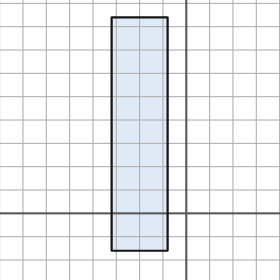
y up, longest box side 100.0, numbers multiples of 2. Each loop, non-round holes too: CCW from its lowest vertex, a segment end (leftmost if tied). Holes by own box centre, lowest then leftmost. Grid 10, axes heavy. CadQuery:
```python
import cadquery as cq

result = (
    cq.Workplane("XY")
    .moveTo(-32.0, -16.0)
    .lineTo(-8.0, -16.0)
    .lineTo(-8.0, 84.0)
    .lineTo(-32.0, 84.0)
    .close()
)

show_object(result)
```